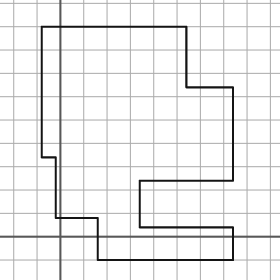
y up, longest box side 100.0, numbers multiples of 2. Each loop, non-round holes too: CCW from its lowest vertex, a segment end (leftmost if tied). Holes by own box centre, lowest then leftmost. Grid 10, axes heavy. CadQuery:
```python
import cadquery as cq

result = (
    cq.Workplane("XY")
    .moveTo(16.0, -10.0)
    .lineTo(74.0, -10.0)
    .lineTo(74.0, 4.0)
    .lineTo(34.0, 4.0)
    .lineTo(34.0, 24.0)
    .lineTo(74.0, 24.0)
    .lineTo(74.0, 64.0)
    .lineTo(54.0, 64.0)
    .lineTo(54.0, 90.0)
    .lineTo(-8.0, 90.0)
    .lineTo(-8.0, 34.0)
    .lineTo(-2.0, 34.0)
    .lineTo(-2.0, 8.0)
    .lineTo(16.0, 8.0)
    .close()
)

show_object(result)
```